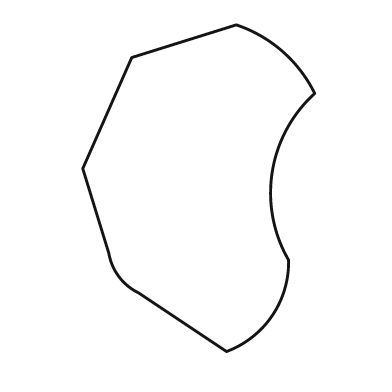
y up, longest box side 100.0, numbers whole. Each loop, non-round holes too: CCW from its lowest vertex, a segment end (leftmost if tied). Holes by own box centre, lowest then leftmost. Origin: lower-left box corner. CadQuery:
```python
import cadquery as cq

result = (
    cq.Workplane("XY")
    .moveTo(44.0, 0.0)
    .threePointArc((58.0, 11.0), (63.0, 28.0))
    .threePointArc((58.0, 55.0), (71.0, 79.0))
    .threePointArc((61.0, 92.0), (47.0, 100.0))
    .lineTo(15.0, 90.0)
    .lineTo(0.0, 56.0)
    .lineTo(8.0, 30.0)
    .threePointArc((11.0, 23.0), (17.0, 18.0))
    .close()
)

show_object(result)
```